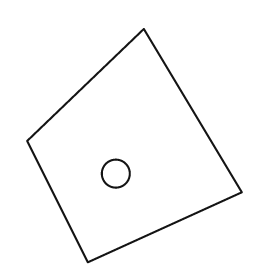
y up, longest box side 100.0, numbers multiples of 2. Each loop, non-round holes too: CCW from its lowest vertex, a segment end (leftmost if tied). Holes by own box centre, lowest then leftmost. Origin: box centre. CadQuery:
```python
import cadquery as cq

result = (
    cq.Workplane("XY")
    .moveTo(-20.0, -50.0)
    .lineTo(46.0, -20.0)
    .lineTo(4.0, 50.0)
    .lineTo(-46.0, 2.0)
    .close()
    .moveTo(-8.0, -12.0)
    .circle(6.0)
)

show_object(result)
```